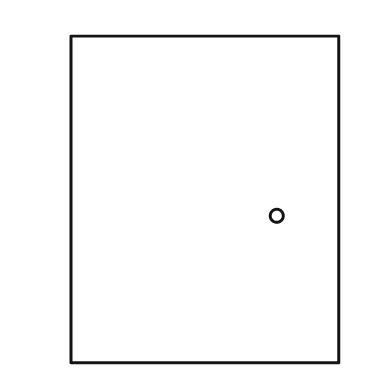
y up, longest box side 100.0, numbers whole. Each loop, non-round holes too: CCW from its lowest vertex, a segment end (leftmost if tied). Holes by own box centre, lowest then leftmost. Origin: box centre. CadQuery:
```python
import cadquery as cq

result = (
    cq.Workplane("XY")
    .moveTo(-41.0, -50.0)
    .lineTo(41.0, -50.0)
    .lineTo(41.0, 50.0)
    .lineTo(-41.0, 50.0)
    .close()
    .moveTo(22.0, -5.0)
    .circle(2.0)
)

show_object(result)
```